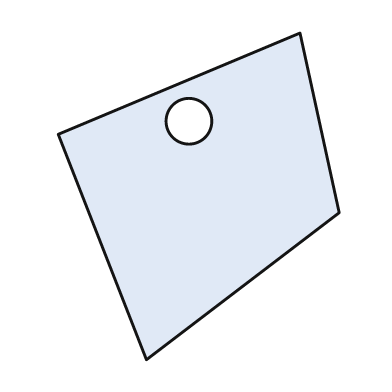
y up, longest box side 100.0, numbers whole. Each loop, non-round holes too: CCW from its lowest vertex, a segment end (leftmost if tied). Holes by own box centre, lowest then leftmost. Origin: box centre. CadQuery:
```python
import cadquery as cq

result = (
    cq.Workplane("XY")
    .moveTo(-16.0, -50.0)
    .lineTo(43.0, -5.0)
    .lineTo(31.0, 50.0)
    .lineTo(-43.0, 19.0)
    .close()
    .moveTo(-3.0, 23.0)
    .circle(7.0)
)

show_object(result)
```